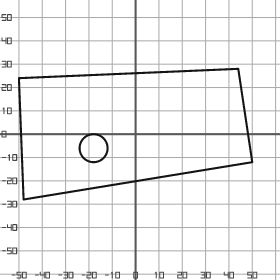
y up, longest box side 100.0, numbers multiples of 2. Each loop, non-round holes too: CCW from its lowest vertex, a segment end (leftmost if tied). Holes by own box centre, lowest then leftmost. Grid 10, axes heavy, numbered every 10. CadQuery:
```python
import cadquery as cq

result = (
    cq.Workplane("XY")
    .moveTo(-48.0, -28.0)
    .lineTo(50.0, -12.0)
    .lineTo(44.0, 28.0)
    .lineTo(-50.0, 24.0)
    .close()
    .moveTo(-18.0, -6.0)
    .circle(6.0)
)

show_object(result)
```